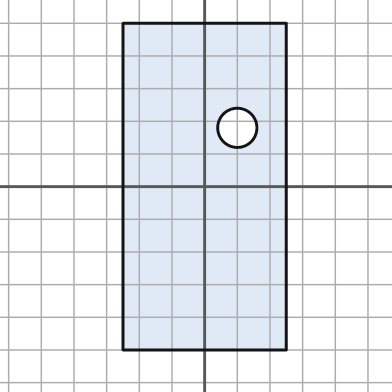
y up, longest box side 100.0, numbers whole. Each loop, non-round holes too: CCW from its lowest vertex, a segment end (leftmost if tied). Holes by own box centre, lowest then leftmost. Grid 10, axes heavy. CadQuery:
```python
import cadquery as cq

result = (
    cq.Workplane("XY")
    .moveTo(-25.0, -50.0)
    .lineTo(25.0, -50.0)
    .lineTo(25.0, 50.0)
    .lineTo(-25.0, 50.0)
    .close()
    .moveTo(10.0, 18.0)
    .circle(6.0)
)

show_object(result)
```